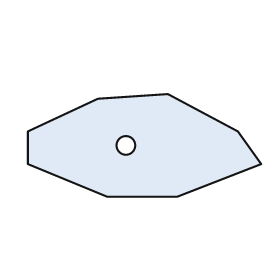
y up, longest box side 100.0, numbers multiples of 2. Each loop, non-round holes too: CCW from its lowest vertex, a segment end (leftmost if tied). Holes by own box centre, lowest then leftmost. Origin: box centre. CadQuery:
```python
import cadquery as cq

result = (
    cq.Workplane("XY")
    .moveTo(-16.0, -22.0)
    .lineTo(14.0, -22.0)
    .lineTo(50.0, -8.0)
    .lineTo(40.0, 6.0)
    .lineTo(10.0, 22.0)
    .lineTo(-20.0, 20.0)
    .lineTo(-50.0, 6.0)
    .lineTo(-50.0, -8.0)
    .close()
    .moveTo(-8.0, 0.0)
    .circle(4.0)
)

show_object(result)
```